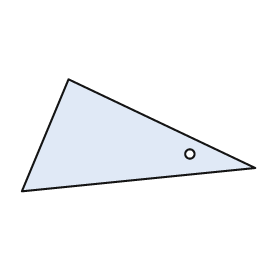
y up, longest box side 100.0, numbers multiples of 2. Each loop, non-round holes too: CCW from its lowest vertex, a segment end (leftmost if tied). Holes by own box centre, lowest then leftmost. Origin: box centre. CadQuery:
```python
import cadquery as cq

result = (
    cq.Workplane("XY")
    .moveTo(-50.0, -24.0)
    .lineTo(50.0, -14.0)
    .lineTo(-30.0, 24.0)
    .close()
    .moveTo(22.0, -8.0)
    .circle(2.0)
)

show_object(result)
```